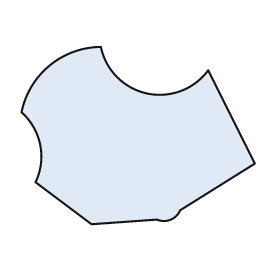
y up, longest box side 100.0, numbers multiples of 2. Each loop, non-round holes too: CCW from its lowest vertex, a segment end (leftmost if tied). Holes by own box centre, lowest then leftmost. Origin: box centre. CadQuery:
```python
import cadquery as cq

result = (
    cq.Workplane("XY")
    .moveTo(-20.0, -38.0)
    .lineTo(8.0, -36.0)
    .threePointArc((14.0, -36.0), (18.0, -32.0))
    .lineTo(50.0, -12.0)
    .lineTo(30.0, 28.0)
    .threePointArc((4.0, 18.0), (-16.0, 38.0))
    .threePointArc((-38.0, 30.0), (-50.0, 10.0))
    .threePointArc((-42.0, -4.0), (-44.0, -20.0))
    .close()
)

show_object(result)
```